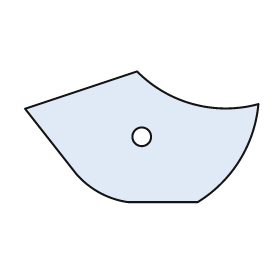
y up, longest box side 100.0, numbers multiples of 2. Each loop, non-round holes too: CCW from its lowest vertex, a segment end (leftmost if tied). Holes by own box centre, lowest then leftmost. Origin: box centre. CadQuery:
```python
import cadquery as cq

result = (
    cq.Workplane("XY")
    .moveTo(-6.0, -28.0)
    .lineTo(24.0, -28.0)
    .threePointArc((42.0, -10.0), (50.0, 14.0))
    .threePointArc((22.0, 14.0), (-2.0, 28.0))
    .lineTo(-50.0, 12.0)
    .lineTo(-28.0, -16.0)
    .threePointArc((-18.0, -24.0), (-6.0, -28.0))
    .close()
    .moveTo(0.0, 0.0)
    .circle(4.0)
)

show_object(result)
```